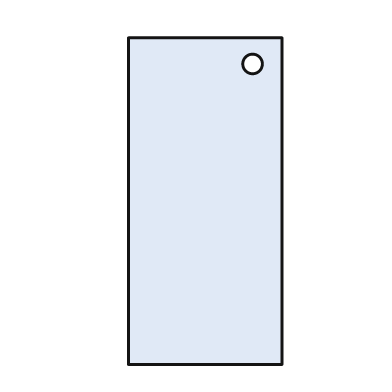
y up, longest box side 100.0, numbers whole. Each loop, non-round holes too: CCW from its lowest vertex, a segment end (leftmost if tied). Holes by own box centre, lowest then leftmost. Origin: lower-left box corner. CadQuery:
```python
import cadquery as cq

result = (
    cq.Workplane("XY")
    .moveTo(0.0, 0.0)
    .lineTo(47.0, 0.0)
    .lineTo(47.0, 100.0)
    .lineTo(0.0, 100.0)
    .close()
    .moveTo(38.0, 92.0)
    .circle(3.0)
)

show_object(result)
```